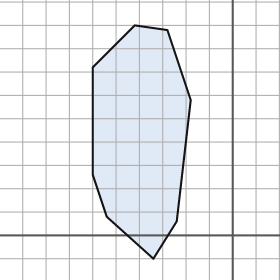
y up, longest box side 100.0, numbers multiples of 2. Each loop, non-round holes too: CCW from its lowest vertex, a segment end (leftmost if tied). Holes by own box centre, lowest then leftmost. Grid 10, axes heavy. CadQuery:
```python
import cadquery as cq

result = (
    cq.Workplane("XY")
    .moveTo(-34.0, -10.0)
    .lineTo(-24.0, 6.0)
    .lineTo(-18.0, 58.0)
    .lineTo(-28.0, 88.0)
    .lineTo(-42.0, 90.0)
    .lineTo(-60.0, 72.0)
    .lineTo(-60.0, 26.0)
    .lineTo(-54.0, 8.0)
    .close()
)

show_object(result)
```